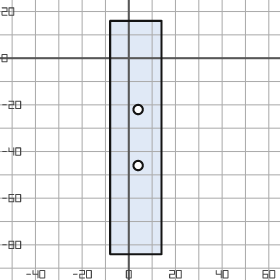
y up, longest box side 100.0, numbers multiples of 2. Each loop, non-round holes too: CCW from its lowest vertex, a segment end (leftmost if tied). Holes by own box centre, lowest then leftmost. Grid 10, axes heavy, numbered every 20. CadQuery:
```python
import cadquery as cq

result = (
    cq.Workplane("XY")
    .moveTo(-8.0, -84.0)
    .lineTo(14.0, -84.0)
    .lineTo(14.0, 16.0)
    .lineTo(-8.0, 16.0)
    .close()
    .moveTo(4.0, -46.0)
    .circle(2.0)
    .moveTo(4.0, -22.0)
    .circle(2.0)
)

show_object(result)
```